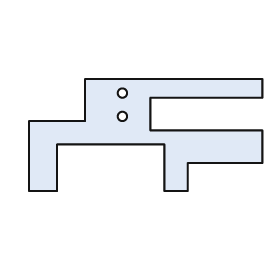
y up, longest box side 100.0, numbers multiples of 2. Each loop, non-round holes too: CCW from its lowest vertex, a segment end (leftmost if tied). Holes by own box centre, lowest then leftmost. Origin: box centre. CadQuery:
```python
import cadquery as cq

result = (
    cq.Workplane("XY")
    .moveTo(-50.0, -24.0)
    .lineTo(-38.0, -24.0)
    .lineTo(-38.0, -4.0)
    .lineTo(8.0, -4.0)
    .lineTo(8.0, -24.0)
    .lineTo(18.0, -24.0)
    .lineTo(18.0, -12.0)
    .lineTo(50.0, -12.0)
    .lineTo(50.0, 2.0)
    .lineTo(2.0, 2.0)
    .lineTo(2.0, 16.0)
    .lineTo(50.0, 16.0)
    .lineTo(50.0, 24.0)
    .lineTo(-26.0, 24.0)
    .lineTo(-26.0, 6.0)
    .lineTo(-50.0, 6.0)
    .close()
    .moveTo(-10.0, 8.0)
    .circle(2.0)
    .moveTo(-10.0, 18.0)
    .circle(2.0)
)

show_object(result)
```